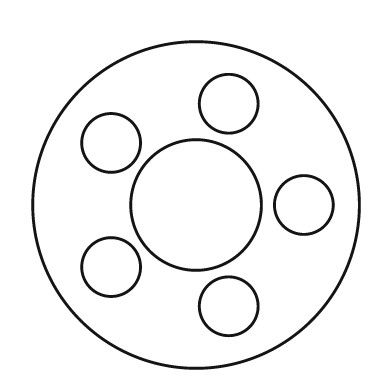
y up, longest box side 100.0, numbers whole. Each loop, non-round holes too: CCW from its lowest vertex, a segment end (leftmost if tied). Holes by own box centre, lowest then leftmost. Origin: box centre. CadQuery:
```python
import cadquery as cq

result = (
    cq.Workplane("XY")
    .moveTo(0.0, 0.0)
    .circle(50.0)
    .moveTo(10.0, -31.0)
    .circle(9.0)
    .moveTo(-26.0, -19.0)
    .circle(9.0)
    .moveTo(0.0, 0.0)
    .circle(20.0)
    .moveTo(33.0, 0.0)
    .circle(9.0)
    .moveTo(-26.0, 19.0)
    .circle(9.0)
    .moveTo(10.0, 31.0)
    .circle(9.0)
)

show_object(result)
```